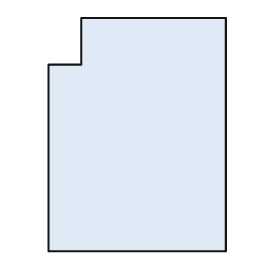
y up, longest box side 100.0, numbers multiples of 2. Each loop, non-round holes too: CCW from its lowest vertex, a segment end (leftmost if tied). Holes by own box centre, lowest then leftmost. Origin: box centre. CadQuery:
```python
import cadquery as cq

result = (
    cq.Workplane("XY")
    .moveTo(-38.0, -50.0)
    .lineTo(38.0, -50.0)
    .lineTo(38.0, 50.0)
    .lineTo(-24.0, 50.0)
    .lineTo(-24.0, 30.0)
    .lineTo(-38.0, 30.0)
    .close()
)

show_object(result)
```